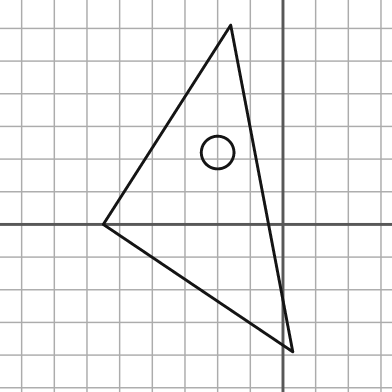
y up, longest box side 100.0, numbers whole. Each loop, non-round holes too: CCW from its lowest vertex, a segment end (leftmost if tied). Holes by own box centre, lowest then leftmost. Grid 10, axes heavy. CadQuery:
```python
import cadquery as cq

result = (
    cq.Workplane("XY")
    .moveTo(3.0, -39.0)
    .lineTo(-16.0, 61.0)
    .lineTo(-55.0, 0.0)
    .close()
    .moveTo(-20.0, 22.0)
    .circle(5.0)
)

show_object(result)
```